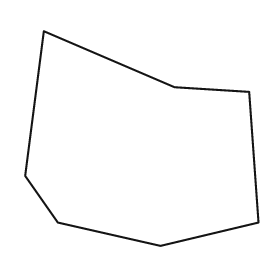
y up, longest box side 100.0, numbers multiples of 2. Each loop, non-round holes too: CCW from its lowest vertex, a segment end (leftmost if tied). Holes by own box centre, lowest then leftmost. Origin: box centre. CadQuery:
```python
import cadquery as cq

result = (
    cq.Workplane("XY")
    .moveTo(8.0, -46.0)
    .lineTo(50.0, -36.0)
    .lineTo(46.0, 20.0)
    .lineTo(14.0, 22.0)
    .lineTo(-42.0, 46.0)
    .lineTo(-50.0, -16.0)
    .lineTo(-36.0, -36.0)
    .close()
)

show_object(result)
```